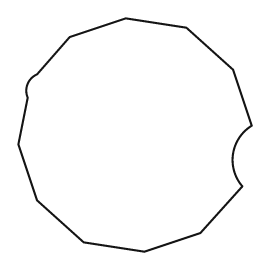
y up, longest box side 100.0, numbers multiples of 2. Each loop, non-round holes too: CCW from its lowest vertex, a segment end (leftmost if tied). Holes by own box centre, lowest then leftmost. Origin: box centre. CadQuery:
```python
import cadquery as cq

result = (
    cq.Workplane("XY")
    .moveTo(4.0, -50.0)
    .lineTo(28.0, -42.0)
    .lineTo(46.0, -22.0)
    .threePointArc((42.0, -8.0), (50.0, 4.0))
    .lineTo(42.0, 28.0)
    .lineTo(22.0, 46.0)
    .lineTo(-4.0, 50.0)
    .lineTo(-28.0, 42.0)
    .lineTo(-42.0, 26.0)
    .threePointArc((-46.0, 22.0), (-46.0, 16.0))
    .lineTo(-50.0, -4.0)
    .lineTo(-42.0, -28.0)
    .lineTo(-22.0, -46.0)
    .close()
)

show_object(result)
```